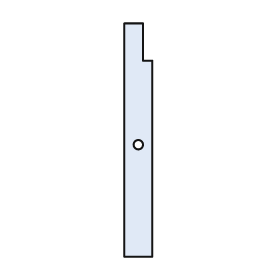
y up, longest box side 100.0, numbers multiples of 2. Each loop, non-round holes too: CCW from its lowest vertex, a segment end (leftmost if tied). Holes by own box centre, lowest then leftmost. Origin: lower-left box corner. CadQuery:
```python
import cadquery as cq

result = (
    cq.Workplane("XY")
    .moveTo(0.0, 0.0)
    .lineTo(12.0, 0.0)
    .lineTo(12.0, 84.0)
    .lineTo(8.0, 84.0)
    .lineTo(8.0, 100.0)
    .lineTo(0.0, 100.0)
    .close()
    .moveTo(6.0, 48.0)
    .circle(2.0)
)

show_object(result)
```